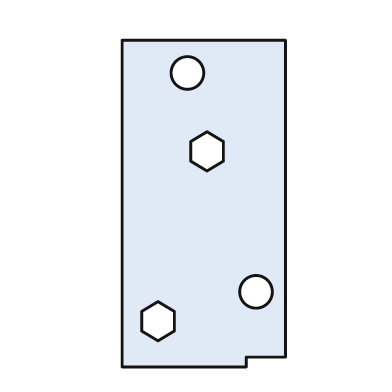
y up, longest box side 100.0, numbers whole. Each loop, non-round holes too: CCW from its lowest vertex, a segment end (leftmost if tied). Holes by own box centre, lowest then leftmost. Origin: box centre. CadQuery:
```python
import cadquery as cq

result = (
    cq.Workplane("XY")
    .moveTo(-25.0, -50.0)
    .lineTo(13.0, -50.0)
    .lineTo(13.0, -47.0)
    .lineTo(25.0, -47.0)
    .lineTo(25.0, 50.0)
    .lineTo(-25.0, 50.0)
    .close()
    .moveTo(-14.0, -42.0)
    .lineTo(-9.0, -39.0)
    .lineTo(-9.0, -33.0)
    .lineTo(-14.0, -30.0)
    .lineTo(-19.0, -33.0)
    .lineTo(-19.0, -39.0)
    .close()
    .moveTo(16.0, -27.0)
    .circle(5.0)
    .moveTo(1.0, 10.0)
    .lineTo(6.0, 13.0)
    .lineTo(6.0, 19.0)
    .lineTo(1.0, 22.0)
    .lineTo(-4.0, 19.0)
    .lineTo(-4.0, 13.0)
    .close()
    .moveTo(-5.0, 40.0)
    .circle(5.0)
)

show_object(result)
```